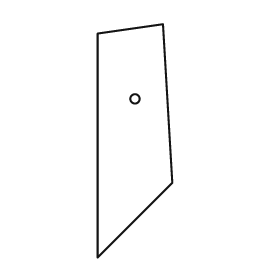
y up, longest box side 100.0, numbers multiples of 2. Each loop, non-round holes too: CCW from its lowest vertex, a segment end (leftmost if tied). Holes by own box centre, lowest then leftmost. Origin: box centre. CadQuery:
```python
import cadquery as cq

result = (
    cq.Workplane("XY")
    .moveTo(-16.0, -50.0)
    .lineTo(16.0, -18.0)
    .lineTo(12.0, 50.0)
    .lineTo(-16.0, 46.0)
    .close()
    .moveTo(0.0, 18.0)
    .circle(2.0)
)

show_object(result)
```